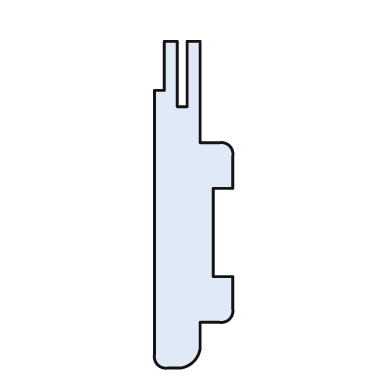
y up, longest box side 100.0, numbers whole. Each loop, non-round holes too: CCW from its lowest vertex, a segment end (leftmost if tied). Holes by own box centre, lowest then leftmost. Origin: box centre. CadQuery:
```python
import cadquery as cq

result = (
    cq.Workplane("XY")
    .moveTo(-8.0, -50.0)
    .lineTo(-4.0, -50.0)
    .threePointArc((0.0, -48.0), (2.0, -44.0))
    .lineTo(2.0, -36.0)
    .lineTo(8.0, -36.0)
    .threePointArc((11.0, -35.0), (12.0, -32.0))
    .lineTo(12.0, -22.0)
    .lineTo(6.0, -22.0)
    .lineTo(6.0, 5.0)
    .lineTo(12.0, 5.0)
    .lineTo(12.0, 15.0)
    .threePointArc((11.0, 18.0), (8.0, 19.0))
    .lineTo(2.0, 19.0)
    .lineTo(2.0, 50.0)
    .lineTo(-2.0, 50.0)
    .lineTo(-2.0, 30.0)
    .lineTo(-5.0, 30.0)
    .lineTo(-5.0, 50.0)
    .lineTo(-9.0, 50.0)
    .lineTo(-9.0, 35.0)
    .lineTo(-12.0, 35.0)
    .lineTo(-12.0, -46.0)
    .threePointArc((-11.0, -49.0), (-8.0, -50.0))
    .close()
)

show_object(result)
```